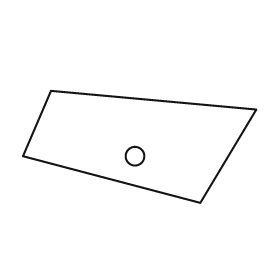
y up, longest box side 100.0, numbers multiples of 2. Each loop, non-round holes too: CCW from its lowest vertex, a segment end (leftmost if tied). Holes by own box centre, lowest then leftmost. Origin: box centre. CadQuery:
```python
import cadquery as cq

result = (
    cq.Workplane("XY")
    .moveTo(26.0, -24.0)
    .lineTo(50.0, 16.0)
    .lineTo(-38.0, 24.0)
    .lineTo(-50.0, -4.0)
    .close()
    .moveTo(-2.0, -4.0)
    .circle(4.0)
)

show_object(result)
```